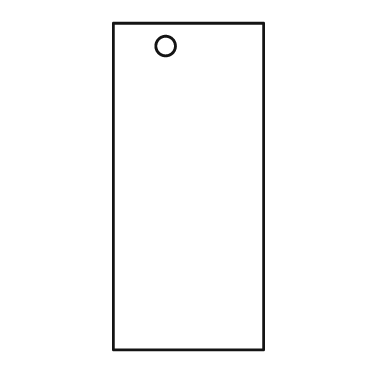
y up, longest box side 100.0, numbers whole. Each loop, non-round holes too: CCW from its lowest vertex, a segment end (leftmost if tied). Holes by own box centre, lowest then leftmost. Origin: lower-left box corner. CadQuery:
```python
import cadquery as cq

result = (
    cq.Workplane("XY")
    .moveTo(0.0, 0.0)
    .lineTo(46.0, 0.0)
    .lineTo(46.0, 100.0)
    .lineTo(0.0, 100.0)
    .close()
    .moveTo(16.0, 93.0)
    .circle(3.0)
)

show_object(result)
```